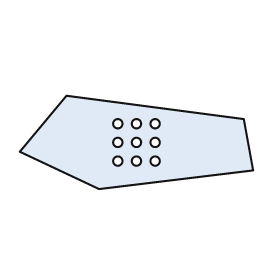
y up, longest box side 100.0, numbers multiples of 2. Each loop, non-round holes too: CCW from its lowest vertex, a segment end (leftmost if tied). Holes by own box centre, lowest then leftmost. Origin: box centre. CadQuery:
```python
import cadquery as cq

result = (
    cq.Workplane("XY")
    .moveTo(-16.0, -20.0)
    .lineTo(50.0, -12.0)
    .lineTo(46.0, 10.0)
    .lineTo(-30.0, 20.0)
    .lineTo(-50.0, -4.0)
    .close()
    .moveTo(-8.0, -8.0)
    .circle(2.0)
    .moveTo(0.0, -8.0)
    .circle(2.0)
    .moveTo(8.0, -8.0)
    .circle(2.0)
    .moveTo(-8.0, 0.0)
    .circle(2.0)
    .moveTo(0.0, 0.0)
    .circle(2.0)
    .moveTo(8.0, 0.0)
    .circle(2.0)
    .moveTo(-8.0, 8.0)
    .circle(2.0)
    .moveTo(0.0, 8.0)
    .circle(2.0)
    .moveTo(8.0, 8.0)
    .circle(2.0)
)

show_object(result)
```